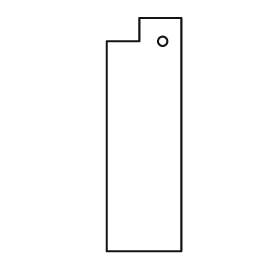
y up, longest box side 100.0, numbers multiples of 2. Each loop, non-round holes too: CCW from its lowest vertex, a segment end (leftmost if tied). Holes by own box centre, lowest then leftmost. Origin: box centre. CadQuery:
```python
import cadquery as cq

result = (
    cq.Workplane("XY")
    .moveTo(-16.0, -50.0)
    .lineTo(16.0, -50.0)
    .lineTo(16.0, 50.0)
    .lineTo(-2.0, 50.0)
    .lineTo(-2.0, 40.0)
    .lineTo(-16.0, 40.0)
    .close()
    .moveTo(8.0, 40.0)
    .circle(2.0)
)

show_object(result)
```